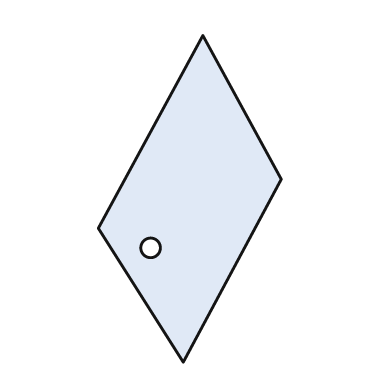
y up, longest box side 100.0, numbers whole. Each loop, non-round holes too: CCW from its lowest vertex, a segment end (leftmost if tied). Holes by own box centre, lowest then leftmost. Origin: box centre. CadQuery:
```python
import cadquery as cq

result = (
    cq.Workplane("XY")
    .moveTo(-2.0, -50.0)
    .lineTo(28.0, 6.0)
    .lineTo(4.0, 50.0)
    .lineTo(-28.0, -9.0)
    .close()
    .moveTo(-12.0, -15.0)
    .circle(3.0)
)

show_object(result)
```